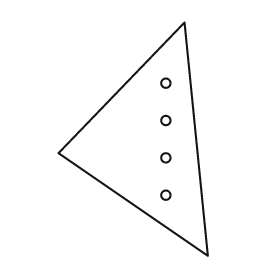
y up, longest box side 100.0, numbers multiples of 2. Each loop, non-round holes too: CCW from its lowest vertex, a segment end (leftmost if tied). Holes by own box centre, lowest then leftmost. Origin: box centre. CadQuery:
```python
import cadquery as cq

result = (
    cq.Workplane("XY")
    .moveTo(32.0, -50.0)
    .lineTo(22.0, 50.0)
    .lineTo(-32.0, -6.0)
    .close()
    .moveTo(14.0, -24.0)
    .circle(2.0)
    .moveTo(14.0, -8.0)
    .circle(2.0)
    .moveTo(14.0, 8.0)
    .circle(2.0)
    .moveTo(14.0, 24.0)
    .circle(2.0)
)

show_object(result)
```